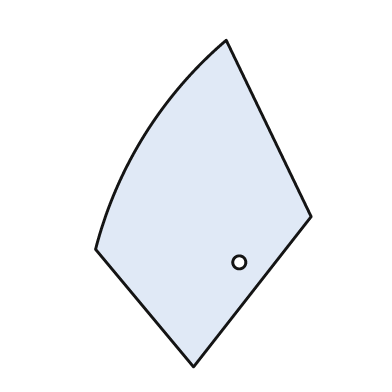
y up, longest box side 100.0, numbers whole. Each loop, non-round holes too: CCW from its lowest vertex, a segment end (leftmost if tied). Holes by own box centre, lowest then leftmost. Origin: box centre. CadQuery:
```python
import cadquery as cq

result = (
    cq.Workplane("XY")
    .moveTo(-3.0, -50.0)
    .lineTo(33.0, -4.0)
    .lineTo(7.0, 50.0)
    .threePointArc((-18.0, 21.0), (-33.0, -14.0))
    .close()
    .moveTo(11.0, -18.0)
    .circle(2.0)
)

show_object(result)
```